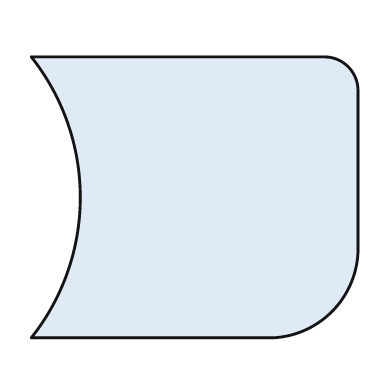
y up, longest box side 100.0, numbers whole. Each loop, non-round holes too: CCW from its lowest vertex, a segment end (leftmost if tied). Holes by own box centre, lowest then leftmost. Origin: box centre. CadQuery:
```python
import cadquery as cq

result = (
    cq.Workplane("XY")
    .moveTo(-50.0, -43.0)
    .lineTo(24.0, -43.0)
    .threePointArc((42.0, -35.0), (50.0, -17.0))
    .lineTo(50.0, 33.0)
    .threePointArc((47.0, 40.0), (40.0, 43.0))
    .lineTo(-50.0, 43.0)
    .threePointArc((-35.0, 0.0), (-50.0, -43.0))
    .close()
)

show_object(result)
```